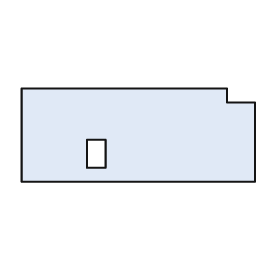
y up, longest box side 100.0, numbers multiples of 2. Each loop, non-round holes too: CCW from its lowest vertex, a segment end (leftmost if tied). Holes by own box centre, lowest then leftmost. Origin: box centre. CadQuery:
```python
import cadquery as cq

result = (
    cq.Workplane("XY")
    .moveTo(-50.0, -20.0)
    .lineTo(50.0, -20.0)
    .lineTo(50.0, 14.0)
    .lineTo(38.0, 14.0)
    .lineTo(38.0, 20.0)
    .lineTo(-50.0, 20.0)
    .close()
    .moveTo(-22.0, -14.0)
    .lineTo(-14.0, -14.0)
    .lineTo(-14.0, -2.0)
    .lineTo(-22.0, -2.0)
    .close()
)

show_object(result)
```